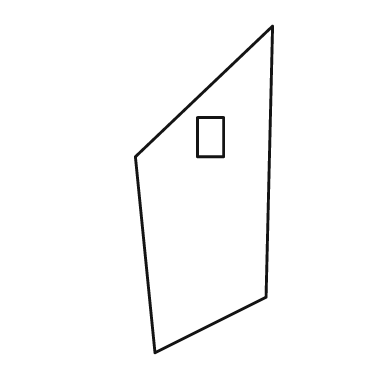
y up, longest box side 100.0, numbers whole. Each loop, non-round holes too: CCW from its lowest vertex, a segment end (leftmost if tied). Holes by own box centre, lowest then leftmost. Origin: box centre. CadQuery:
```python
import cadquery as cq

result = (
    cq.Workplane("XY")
    .moveTo(-15.0, -50.0)
    .lineTo(19.0, -33.0)
    .lineTo(21.0, 50.0)
    .lineTo(-21.0, 10.0)
    .close()
    .moveTo(-2.0, 10.0)
    .lineTo(6.0, 10.0)
    .lineTo(6.0, 22.0)
    .lineTo(-2.0, 22.0)
    .close()
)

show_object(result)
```